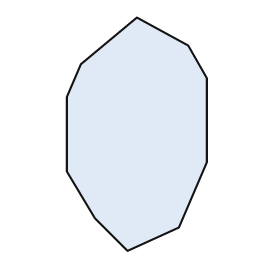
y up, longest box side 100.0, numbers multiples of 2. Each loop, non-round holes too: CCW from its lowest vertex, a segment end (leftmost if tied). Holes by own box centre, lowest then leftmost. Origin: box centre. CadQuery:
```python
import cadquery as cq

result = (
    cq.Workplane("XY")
    .moveTo(-4.0, -50.0)
    .lineTo(18.0, -40.0)
    .lineTo(30.0, -12.0)
    .lineTo(30.0, 24.0)
    .lineTo(22.0, 38.0)
    .lineTo(0.0, 50.0)
    .lineTo(-24.0, 30.0)
    .lineTo(-30.0, 16.0)
    .lineTo(-30.0, -16.0)
    .lineTo(-18.0, -36.0)
    .close()
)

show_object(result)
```